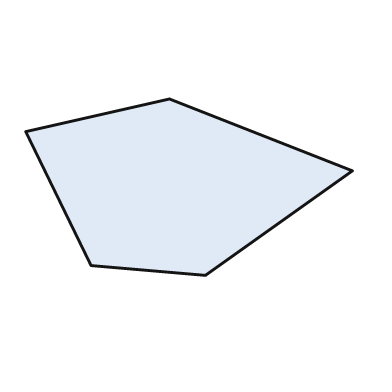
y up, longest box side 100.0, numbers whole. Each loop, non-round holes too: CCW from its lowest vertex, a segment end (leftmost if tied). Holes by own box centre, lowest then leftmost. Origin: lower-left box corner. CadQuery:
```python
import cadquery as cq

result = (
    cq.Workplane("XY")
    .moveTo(55.0, 0.0)
    .lineTo(100.0, 32.0)
    .lineTo(44.0, 54.0)
    .lineTo(0.0, 44.0)
    .lineTo(20.0, 3.0)
    .close()
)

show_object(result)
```